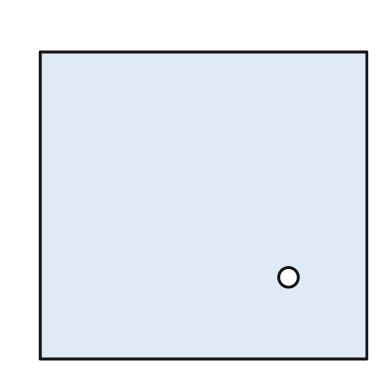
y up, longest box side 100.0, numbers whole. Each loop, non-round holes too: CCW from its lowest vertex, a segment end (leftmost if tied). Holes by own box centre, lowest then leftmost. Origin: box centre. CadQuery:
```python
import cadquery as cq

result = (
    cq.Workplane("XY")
    .moveTo(-50.0, -47.0)
    .lineTo(50.0, -47.0)
    .lineTo(50.0, 47.0)
    .lineTo(-50.0, 47.0)
    .close()
    .moveTo(26.0, -22.0)
    .circle(3.0)
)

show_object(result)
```